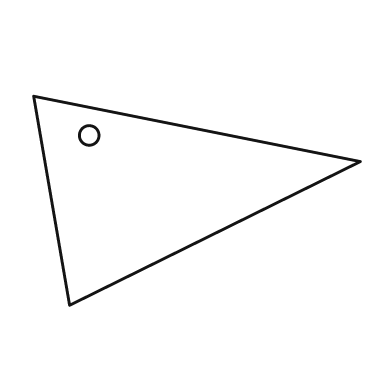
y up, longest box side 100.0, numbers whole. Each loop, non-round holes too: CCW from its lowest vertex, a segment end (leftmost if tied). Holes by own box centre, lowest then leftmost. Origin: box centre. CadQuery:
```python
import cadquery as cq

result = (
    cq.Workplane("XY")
    .moveTo(-39.0, -32.0)
    .lineTo(50.0, 12.0)
    .lineTo(-50.0, 32.0)
    .close()
    .moveTo(-33.0, 20.0)
    .circle(3.0)
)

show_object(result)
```